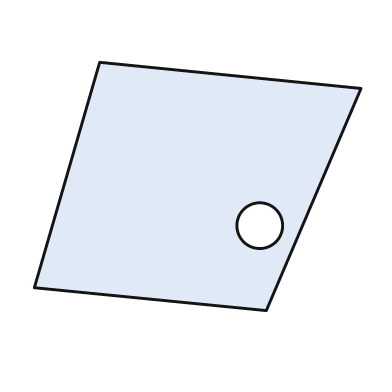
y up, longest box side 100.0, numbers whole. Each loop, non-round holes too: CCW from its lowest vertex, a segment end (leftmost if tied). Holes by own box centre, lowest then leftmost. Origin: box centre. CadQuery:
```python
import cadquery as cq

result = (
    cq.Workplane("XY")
    .moveTo(21.0, -38.0)
    .lineTo(50.0, 30.0)
    .lineTo(-30.0, 38.0)
    .lineTo(-50.0, -31.0)
    .close()
    .moveTo(19.0, -12.0)
    .circle(7.0)
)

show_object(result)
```